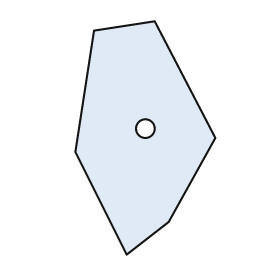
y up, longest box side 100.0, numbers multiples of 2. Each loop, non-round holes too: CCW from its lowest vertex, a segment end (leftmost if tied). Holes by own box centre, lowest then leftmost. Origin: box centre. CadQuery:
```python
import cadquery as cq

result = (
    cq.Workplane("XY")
    .moveTo(-8.0, -50.0)
    .lineTo(10.0, -36.0)
    .lineTo(30.0, 0.0)
    .lineTo(4.0, 50.0)
    .lineTo(-22.0, 46.0)
    .lineTo(-30.0, -6.0)
    .close()
    .moveTo(0.0, 4.0)
    .circle(4.0)
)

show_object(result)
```